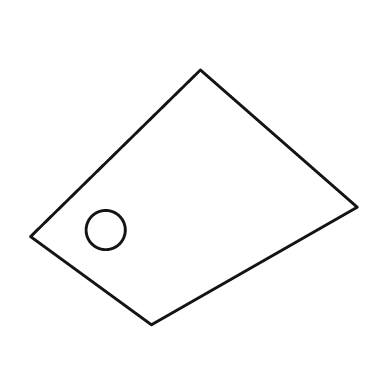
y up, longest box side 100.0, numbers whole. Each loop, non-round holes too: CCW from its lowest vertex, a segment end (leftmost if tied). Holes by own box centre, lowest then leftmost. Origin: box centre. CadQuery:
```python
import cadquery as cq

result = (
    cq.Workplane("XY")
    .moveTo(-13.0, -39.0)
    .lineTo(50.0, -3.0)
    .lineTo(2.0, 39.0)
    .lineTo(-50.0, -12.0)
    .close()
    .moveTo(-27.0, -10.0)
    .circle(6.0)
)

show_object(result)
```